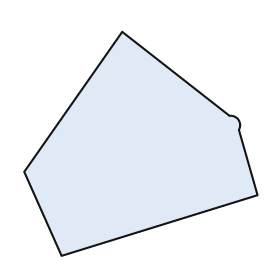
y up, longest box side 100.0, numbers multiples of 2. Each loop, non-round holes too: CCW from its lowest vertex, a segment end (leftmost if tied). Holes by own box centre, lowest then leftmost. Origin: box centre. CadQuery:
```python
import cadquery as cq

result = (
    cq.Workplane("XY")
    .moveTo(-34.0, -48.0)
    .lineTo(50.0, -22.0)
    .lineTo(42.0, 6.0)
    .threePointArc((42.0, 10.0), (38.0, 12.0))
    .lineTo(-8.0, 48.0)
    .lineTo(-50.0, -12.0)
    .close()
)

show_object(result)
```